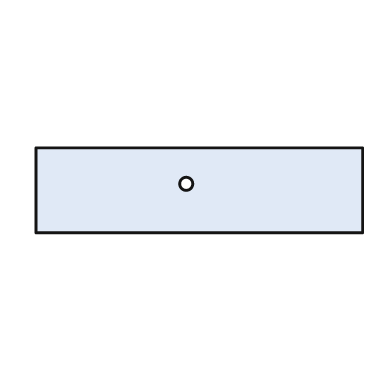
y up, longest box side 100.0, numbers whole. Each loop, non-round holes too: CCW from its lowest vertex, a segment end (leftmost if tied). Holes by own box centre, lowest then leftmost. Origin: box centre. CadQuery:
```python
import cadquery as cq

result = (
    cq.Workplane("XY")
    .moveTo(-50.0, -13.0)
    .lineTo(50.0, -13.0)
    .lineTo(50.0, 13.0)
    .lineTo(-50.0, 13.0)
    .close()
    .moveTo(-4.0, 2.0)
    .circle(2.0)
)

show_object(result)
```